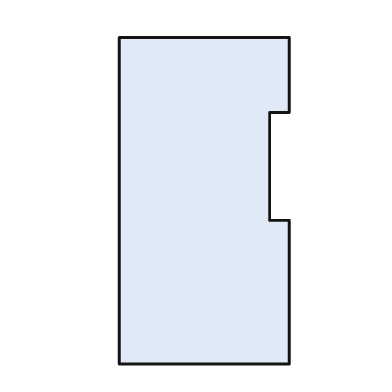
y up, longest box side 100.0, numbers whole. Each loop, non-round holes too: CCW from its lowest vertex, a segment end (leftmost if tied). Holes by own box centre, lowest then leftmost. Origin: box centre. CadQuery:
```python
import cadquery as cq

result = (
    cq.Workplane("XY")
    .moveTo(-26.0, -50.0)
    .lineTo(26.0, -50.0)
    .lineTo(26.0, -6.0)
    .lineTo(20.0, -6.0)
    .lineTo(20.0, 27.0)
    .lineTo(26.0, 27.0)
    .lineTo(26.0, 50.0)
    .lineTo(-26.0, 50.0)
    .close()
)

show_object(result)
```